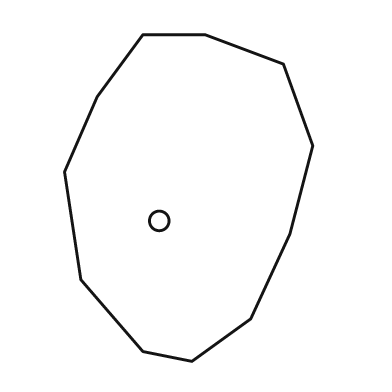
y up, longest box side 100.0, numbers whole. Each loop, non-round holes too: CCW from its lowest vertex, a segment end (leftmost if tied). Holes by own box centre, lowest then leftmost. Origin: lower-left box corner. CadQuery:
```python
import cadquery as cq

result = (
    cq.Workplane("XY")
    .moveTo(39.0, 0.0)
    .lineTo(57.0, 13.0)
    .lineTo(69.0, 39.0)
    .lineTo(76.0, 66.0)
    .lineTo(67.0, 91.0)
    .lineTo(43.0, 100.0)
    .lineTo(24.0, 100.0)
    .lineTo(10.0, 81.0)
    .lineTo(0.0, 58.0)
    .lineTo(5.0, 25.0)
    .lineTo(24.0, 3.0)
    .close()
    .moveTo(29.0, 43.0)
    .circle(3.0)
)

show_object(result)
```